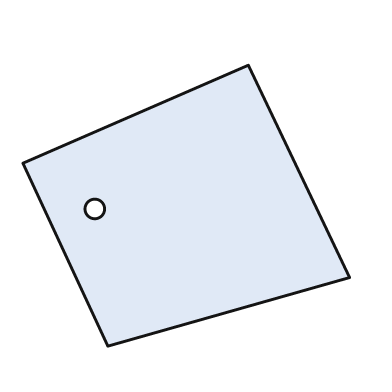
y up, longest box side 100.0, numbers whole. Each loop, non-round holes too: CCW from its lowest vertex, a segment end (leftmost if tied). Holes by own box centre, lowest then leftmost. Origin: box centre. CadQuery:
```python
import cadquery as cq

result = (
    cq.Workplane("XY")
    .moveTo(-24.0, -43.0)
    .lineTo(50.0, -22.0)
    .lineTo(19.0, 43.0)
    .lineTo(-50.0, 13.0)
    .close()
    .moveTo(-28.0, -1.0)
    .circle(3.0)
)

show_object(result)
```